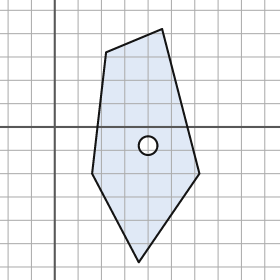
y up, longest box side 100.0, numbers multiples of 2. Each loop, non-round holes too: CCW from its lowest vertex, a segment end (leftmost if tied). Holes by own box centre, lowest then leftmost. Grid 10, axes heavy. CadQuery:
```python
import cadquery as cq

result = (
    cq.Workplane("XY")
    .moveTo(36.0, -58.0)
    .lineTo(62.0, -20.0)
    .lineTo(46.0, 42.0)
    .lineTo(22.0, 32.0)
    .lineTo(16.0, -20.0)
    .close()
    .moveTo(40.0, -8.0)
    .circle(4.0)
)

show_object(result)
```